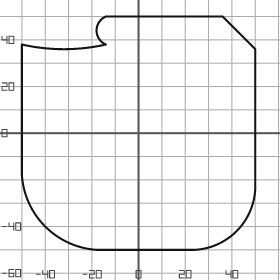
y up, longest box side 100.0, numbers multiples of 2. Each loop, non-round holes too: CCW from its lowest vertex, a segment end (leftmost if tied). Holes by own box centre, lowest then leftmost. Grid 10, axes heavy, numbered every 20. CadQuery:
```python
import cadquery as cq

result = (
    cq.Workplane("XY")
    .moveTo(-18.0, -50.0)
    .lineTo(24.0, -50.0)
    .threePointArc((42.0, -42.0), (50.0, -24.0))
    .lineTo(50.0, 36.0)
    .lineTo(36.0, 50.0)
    .lineTo(-14.0, 50.0)
    .threePointArc((-18.0, 44.0), (-14.0, 38.0))
    .threePointArc((-32.0, 36.0), (-50.0, 38.0))
    .lineTo(-50.0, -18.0)
    .threePointArc((-40.0, -40.0), (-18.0, -50.0))
    .close()
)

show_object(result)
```